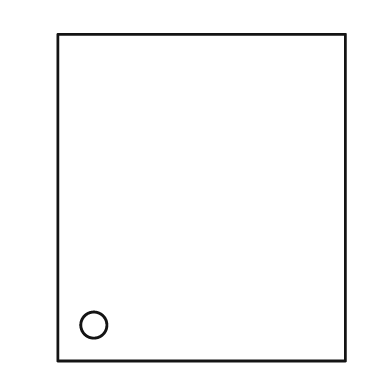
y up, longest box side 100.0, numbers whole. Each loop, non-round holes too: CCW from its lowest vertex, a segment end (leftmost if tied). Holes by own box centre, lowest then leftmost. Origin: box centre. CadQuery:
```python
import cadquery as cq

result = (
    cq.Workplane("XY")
    .moveTo(-44.0, -50.0)
    .lineTo(44.0, -50.0)
    .lineTo(44.0, 50.0)
    .lineTo(-44.0, 50.0)
    .close()
    .moveTo(-33.0, -39.0)
    .circle(4.0)
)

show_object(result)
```